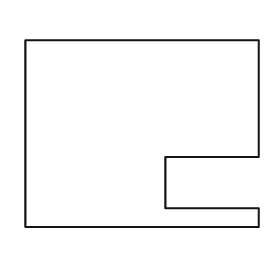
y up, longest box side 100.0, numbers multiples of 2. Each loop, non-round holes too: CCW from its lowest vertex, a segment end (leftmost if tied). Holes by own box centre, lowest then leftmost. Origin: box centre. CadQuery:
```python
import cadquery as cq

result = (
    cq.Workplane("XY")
    .moveTo(-50.0, -40.0)
    .lineTo(50.0, -40.0)
    .lineTo(50.0, -32.0)
    .lineTo(10.0, -32.0)
    .lineTo(10.0, -10.0)
    .lineTo(50.0, -10.0)
    .lineTo(50.0, 40.0)
    .lineTo(-50.0, 40.0)
    .close()
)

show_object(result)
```